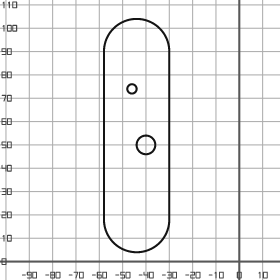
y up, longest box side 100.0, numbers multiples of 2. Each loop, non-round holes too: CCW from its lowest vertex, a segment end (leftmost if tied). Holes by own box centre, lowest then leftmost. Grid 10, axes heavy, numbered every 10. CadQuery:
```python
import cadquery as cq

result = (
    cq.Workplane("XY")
    .moveTo(-58.0, 18.0)
    .threePointArc((-44.0, 4.0), (-30.0, 18.0))
    .lineTo(-30.0, 90.0)
    .threePointArc((-44.0, 104.0), (-58.0, 90.0))
    .close()
    .moveTo(-40.0, 50.0)
    .circle(4.0)
    .moveTo(-46.0, 74.0)
    .circle(2.0)
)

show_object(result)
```